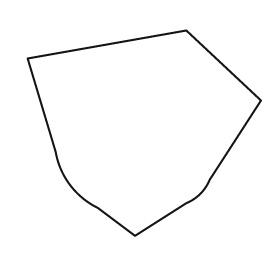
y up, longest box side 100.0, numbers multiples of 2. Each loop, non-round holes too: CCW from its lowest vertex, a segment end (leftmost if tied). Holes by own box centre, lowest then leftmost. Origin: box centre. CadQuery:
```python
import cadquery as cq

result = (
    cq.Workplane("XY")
    .moveTo(-4.0, -44.0)
    .lineTo(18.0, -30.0)
    .threePointArc((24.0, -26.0), (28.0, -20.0))
    .lineTo(50.0, 14.0)
    .lineTo(18.0, 44.0)
    .lineTo(-50.0, 32.0)
    .lineTo(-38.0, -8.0)
    .threePointArc((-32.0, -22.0), (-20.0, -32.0))
    .close()
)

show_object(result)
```